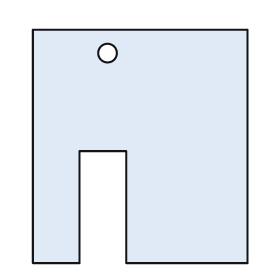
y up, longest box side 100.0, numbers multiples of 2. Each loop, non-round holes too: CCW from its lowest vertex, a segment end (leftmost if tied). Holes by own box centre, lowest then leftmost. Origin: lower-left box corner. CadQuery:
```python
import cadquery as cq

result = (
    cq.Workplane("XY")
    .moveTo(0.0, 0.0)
    .lineTo(20.0, 0.0)
    .lineTo(20.0, 48.0)
    .lineTo(40.0, 48.0)
    .lineTo(40.0, 0.0)
    .lineTo(92.0, 0.0)
    .lineTo(92.0, 100.0)
    .lineTo(0.0, 100.0)
    .close()
    .moveTo(32.0, 90.0)
    .circle(4.0)
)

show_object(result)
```